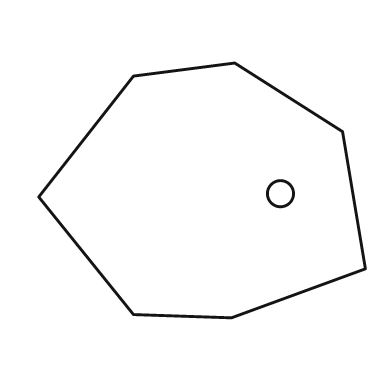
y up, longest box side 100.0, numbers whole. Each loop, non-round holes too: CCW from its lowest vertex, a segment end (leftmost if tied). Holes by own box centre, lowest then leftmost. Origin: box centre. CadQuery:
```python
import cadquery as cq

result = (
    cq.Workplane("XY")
    .moveTo(9.0, -39.0)
    .lineTo(50.0, -24.0)
    .lineTo(43.0, 18.0)
    .lineTo(10.0, 39.0)
    .lineTo(-21.0, 35.0)
    .lineTo(-50.0, -2.0)
    .lineTo(-21.0, -38.0)
    .close()
    .moveTo(24.0, -1.0)
    .circle(4.0)
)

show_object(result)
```